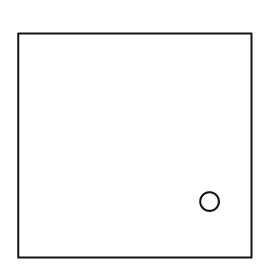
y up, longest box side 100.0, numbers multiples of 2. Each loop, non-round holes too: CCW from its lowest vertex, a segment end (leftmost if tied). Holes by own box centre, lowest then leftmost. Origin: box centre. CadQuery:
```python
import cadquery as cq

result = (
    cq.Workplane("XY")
    .moveTo(-50.0, -48.0)
    .lineTo(50.0, -48.0)
    .lineTo(50.0, 48.0)
    .lineTo(-50.0, 48.0)
    .close()
    .moveTo(32.0, -24.0)
    .circle(4.0)
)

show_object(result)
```